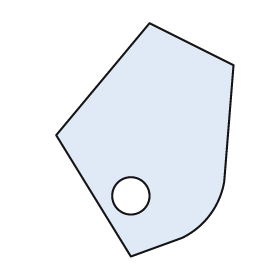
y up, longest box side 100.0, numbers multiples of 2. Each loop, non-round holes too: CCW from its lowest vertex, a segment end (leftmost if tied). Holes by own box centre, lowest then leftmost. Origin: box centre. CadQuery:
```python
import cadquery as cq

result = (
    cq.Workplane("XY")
    .moveTo(-6.0, -50.0)
    .lineTo(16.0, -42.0)
    .threePointArc((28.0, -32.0), (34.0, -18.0))
    .lineTo(38.0, 32.0)
    .lineTo(2.0, 50.0)
    .lineTo(-38.0, 2.0)
    .close()
    .moveTo(-6.0, -24.0)
    .circle(8.0)
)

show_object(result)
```